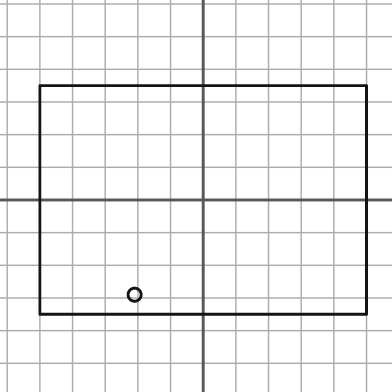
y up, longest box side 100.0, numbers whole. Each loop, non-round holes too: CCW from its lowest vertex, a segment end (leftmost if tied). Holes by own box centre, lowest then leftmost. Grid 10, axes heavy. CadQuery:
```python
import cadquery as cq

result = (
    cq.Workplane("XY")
    .moveTo(-50.0, -35.0)
    .lineTo(50.0, -35.0)
    .lineTo(50.0, 35.0)
    .lineTo(-50.0, 35.0)
    .close()
    .moveTo(-21.0, -29.0)
    .circle(2.0)
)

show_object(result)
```